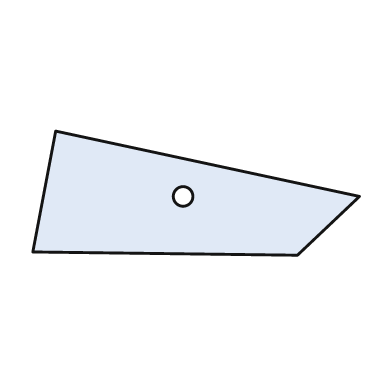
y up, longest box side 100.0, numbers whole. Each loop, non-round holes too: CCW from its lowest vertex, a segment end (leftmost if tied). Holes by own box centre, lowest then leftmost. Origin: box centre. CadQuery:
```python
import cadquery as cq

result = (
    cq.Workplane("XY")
    .moveTo(31.0, -19.0)
    .lineTo(50.0, -1.0)
    .lineTo(-43.0, 19.0)
    .lineTo(-50.0, -18.0)
    .close()
    .moveTo(-4.0, -1.0)
    .circle(3.0)
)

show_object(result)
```